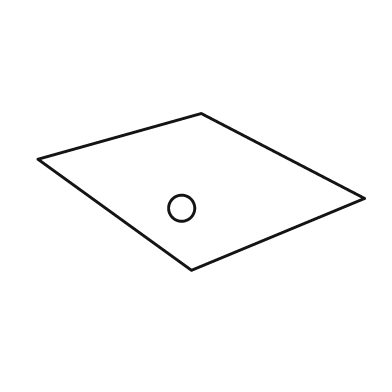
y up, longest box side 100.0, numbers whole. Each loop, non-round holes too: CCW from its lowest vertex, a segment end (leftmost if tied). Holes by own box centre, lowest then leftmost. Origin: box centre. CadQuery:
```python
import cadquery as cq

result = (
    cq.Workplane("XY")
    .moveTo(-3.0, -24.0)
    .lineTo(50.0, -2.0)
    .lineTo(0.0, 24.0)
    .lineTo(-50.0, 10.0)
    .close()
    .moveTo(-6.0, -5.0)
    .circle(4.0)
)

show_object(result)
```